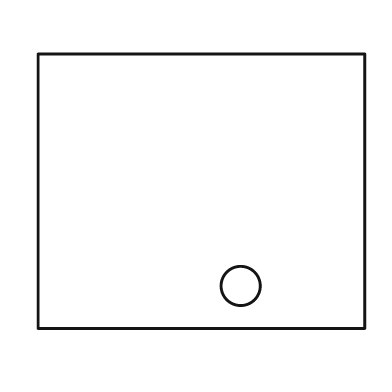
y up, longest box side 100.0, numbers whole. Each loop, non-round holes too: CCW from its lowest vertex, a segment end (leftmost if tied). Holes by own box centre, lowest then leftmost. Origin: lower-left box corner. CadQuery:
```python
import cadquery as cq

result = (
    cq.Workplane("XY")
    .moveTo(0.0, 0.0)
    .lineTo(100.0, 0.0)
    .lineTo(100.0, 84.0)
    .lineTo(0.0, 84.0)
    .close()
    .moveTo(62.0, 13.0)
    .circle(6.0)
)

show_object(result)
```